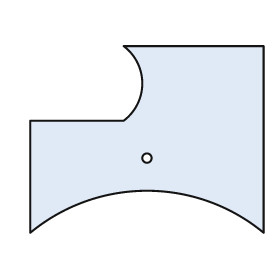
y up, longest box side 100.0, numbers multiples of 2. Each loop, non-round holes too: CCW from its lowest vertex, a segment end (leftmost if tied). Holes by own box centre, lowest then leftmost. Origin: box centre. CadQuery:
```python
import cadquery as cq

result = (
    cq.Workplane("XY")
    .moveTo(-50.0, -40.0)
    .threePointArc((0.0, -22.0), (50.0, -40.0))
    .lineTo(50.0, 40.0)
    .lineTo(-10.0, 40.0)
    .threePointArc((-2.0, 24.0), (-10.0, 8.0))
    .lineTo(-50.0, 8.0)
    .close()
    .moveTo(0.0, -8.0)
    .circle(2.0)
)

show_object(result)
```